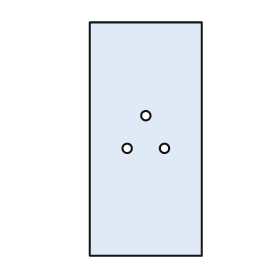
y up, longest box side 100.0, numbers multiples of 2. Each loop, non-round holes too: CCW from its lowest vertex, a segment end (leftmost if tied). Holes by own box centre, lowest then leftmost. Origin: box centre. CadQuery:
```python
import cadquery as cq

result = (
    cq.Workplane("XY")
    .moveTo(-24.0, -50.0)
    .lineTo(24.0, -50.0)
    .lineTo(24.0, 50.0)
    .lineTo(-24.0, 50.0)
    .close()
    .moveTo(-8.0, -4.0)
    .circle(2.0)
    .moveTo(8.0, -4.0)
    .circle(2.0)
    .moveTo(0.0, 10.0)
    .circle(2.0)
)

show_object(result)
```